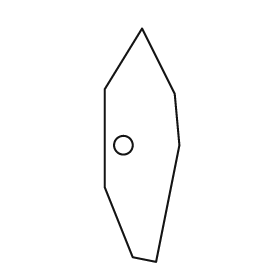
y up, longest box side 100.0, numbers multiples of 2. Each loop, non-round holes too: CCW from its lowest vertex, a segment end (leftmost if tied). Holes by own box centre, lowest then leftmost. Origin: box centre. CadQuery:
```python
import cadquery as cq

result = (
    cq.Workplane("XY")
    .moveTo(6.0, -50.0)
    .lineTo(16.0, 0.0)
    .lineTo(14.0, 22.0)
    .lineTo(0.0, 50.0)
    .lineTo(-16.0, 24.0)
    .lineTo(-16.0, -18.0)
    .lineTo(-4.0, -48.0)
    .close()
    .moveTo(-8.0, 0.0)
    .circle(4.0)
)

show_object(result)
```